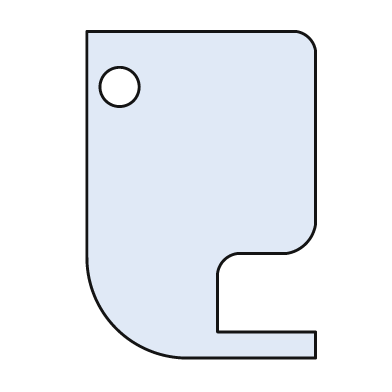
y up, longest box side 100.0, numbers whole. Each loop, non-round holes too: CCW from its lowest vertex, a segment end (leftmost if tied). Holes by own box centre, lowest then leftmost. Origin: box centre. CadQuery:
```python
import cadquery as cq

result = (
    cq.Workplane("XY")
    .moveTo(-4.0, -50.0)
    .lineTo(35.0, -50.0)
    .lineTo(35.0, -42.0)
    .lineTo(5.0, -42.0)
    .lineTo(5.0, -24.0)
    .threePointArc((7.0, -20.0), (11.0, -18.0))
    .lineTo(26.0, -18.0)
    .threePointArc((32.0, -15.0), (35.0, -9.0))
    .lineTo(35.0, 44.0)
    .threePointArc((33.0, 48.0), (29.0, 50.0))
    .lineTo(-35.0, 50.0)
    .lineTo(-35.0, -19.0)
    .threePointArc((-26.0, -41.0), (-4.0, -50.0))
    .close()
    .moveTo(-25.0, 33.0)
    .circle(6.0)
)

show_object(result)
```